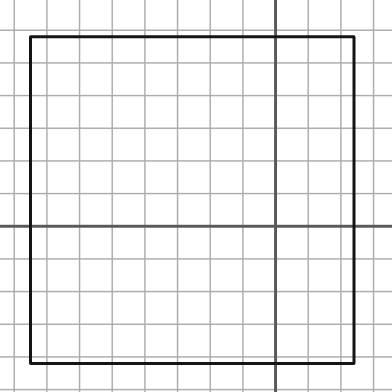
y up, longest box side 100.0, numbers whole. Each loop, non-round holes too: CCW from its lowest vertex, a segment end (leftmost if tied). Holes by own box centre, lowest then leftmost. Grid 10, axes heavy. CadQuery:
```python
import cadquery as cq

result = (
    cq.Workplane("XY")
    .moveTo(-75.0, -42.0)
    .lineTo(24.0, -42.0)
    .lineTo(24.0, 58.0)
    .lineTo(-75.0, 58.0)
    .close()
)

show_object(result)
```